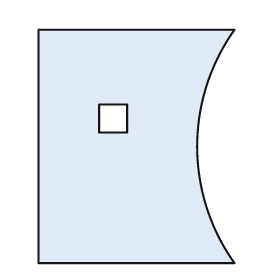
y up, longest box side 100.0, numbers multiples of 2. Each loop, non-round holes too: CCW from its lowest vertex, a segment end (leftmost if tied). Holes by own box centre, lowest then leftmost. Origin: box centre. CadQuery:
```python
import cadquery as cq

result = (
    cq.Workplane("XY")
    .moveTo(-42.0, -50.0)
    .lineTo(42.0, -50.0)
    .threePointArc((26.0, 0.0), (42.0, 50.0))
    .lineTo(-42.0, 50.0)
    .close()
    .moveTo(-16.0, 6.0)
    .lineTo(-4.0, 6.0)
    .lineTo(-4.0, 18.0)
    .lineTo(-16.0, 18.0)
    .close()
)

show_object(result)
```